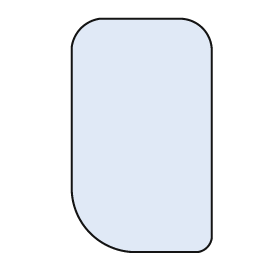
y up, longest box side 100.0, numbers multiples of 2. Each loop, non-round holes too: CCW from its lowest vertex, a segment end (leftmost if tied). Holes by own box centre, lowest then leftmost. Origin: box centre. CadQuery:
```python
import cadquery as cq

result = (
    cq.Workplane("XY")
    .moveTo(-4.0, -50.0)
    .lineTo(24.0, -50.0)
    .threePointArc((28.0, -48.0), (30.0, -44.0))
    .lineTo(30.0, 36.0)
    .threePointArc((26.0, 46.0), (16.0, 50.0))
    .lineTo(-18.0, 50.0)
    .threePointArc((-26.0, 46.0), (-30.0, 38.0))
    .lineTo(-30.0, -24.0)
    .threePointArc((-22.0, -42.0), (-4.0, -50.0))
    .close()
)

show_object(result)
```